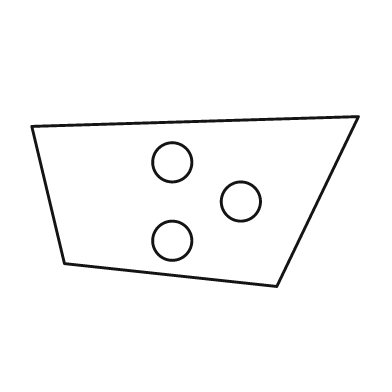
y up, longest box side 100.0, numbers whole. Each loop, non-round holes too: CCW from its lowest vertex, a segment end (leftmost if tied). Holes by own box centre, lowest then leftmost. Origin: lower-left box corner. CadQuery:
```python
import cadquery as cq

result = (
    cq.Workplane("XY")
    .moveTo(75.0, 0.0)
    .lineTo(100.0, 52.0)
    .lineTo(0.0, 49.0)
    .lineTo(10.0, 7.0)
    .close()
    .moveTo(43.0, 14.0)
    .circle(6.0)
    .moveTo(64.0, 26.0)
    .circle(6.0)
    .moveTo(43.0, 38.0)
    .circle(6.0)
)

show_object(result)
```